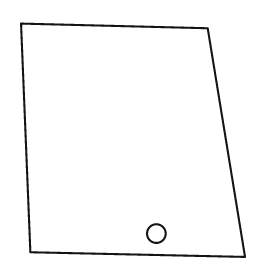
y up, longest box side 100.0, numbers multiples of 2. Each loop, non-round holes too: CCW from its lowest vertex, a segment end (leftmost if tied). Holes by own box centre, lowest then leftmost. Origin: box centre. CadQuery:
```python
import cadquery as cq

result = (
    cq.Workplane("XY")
    .moveTo(48.0, -50.0)
    .lineTo(32.0, 48.0)
    .lineTo(-48.0, 50.0)
    .lineTo(-44.0, -48.0)
    .close()
    .moveTo(10.0, -40.0)
    .circle(4.0)
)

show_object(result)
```